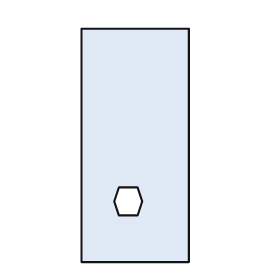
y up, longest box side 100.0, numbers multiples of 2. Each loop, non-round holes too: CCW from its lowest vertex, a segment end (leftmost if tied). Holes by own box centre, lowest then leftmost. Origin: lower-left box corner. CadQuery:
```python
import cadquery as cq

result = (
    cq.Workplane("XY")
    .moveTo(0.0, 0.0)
    .lineTo(46.0, 0.0)
    .lineTo(46.0, 100.0)
    .lineTo(0.0, 100.0)
    .close()
    .moveTo(16.0, 20.0)
    .lineTo(24.0, 20.0)
    .lineTo(26.0, 26.0)
    .lineTo(24.0, 32.0)
    .lineTo(16.0, 32.0)
    .lineTo(14.0, 26.0)
    .close()
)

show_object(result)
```